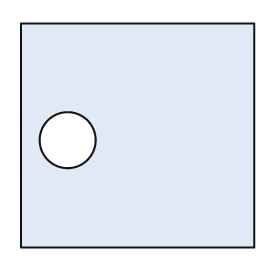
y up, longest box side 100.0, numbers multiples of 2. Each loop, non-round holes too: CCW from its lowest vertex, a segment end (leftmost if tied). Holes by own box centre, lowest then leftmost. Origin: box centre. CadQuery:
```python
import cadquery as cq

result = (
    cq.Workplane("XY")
    .moveTo(-50.0, -48.0)
    .lineTo(50.0, -48.0)
    .lineTo(50.0, 48.0)
    .lineTo(-50.0, 48.0)
    .close()
    .moveTo(-30.0, -2.0)
    .circle(12.0)
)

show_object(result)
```